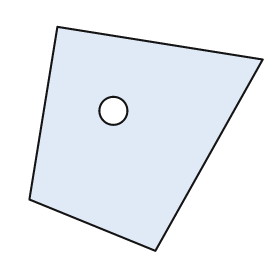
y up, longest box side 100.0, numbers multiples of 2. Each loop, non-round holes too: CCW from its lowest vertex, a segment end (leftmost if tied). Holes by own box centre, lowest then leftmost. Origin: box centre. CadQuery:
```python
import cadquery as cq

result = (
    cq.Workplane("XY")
    .moveTo(4.0, -48.0)
    .lineTo(50.0, 34.0)
    .lineTo(-38.0, 48.0)
    .lineTo(-50.0, -26.0)
    .close()
    .moveTo(-14.0, 12.0)
    .circle(6.0)
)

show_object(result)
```